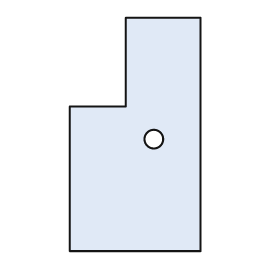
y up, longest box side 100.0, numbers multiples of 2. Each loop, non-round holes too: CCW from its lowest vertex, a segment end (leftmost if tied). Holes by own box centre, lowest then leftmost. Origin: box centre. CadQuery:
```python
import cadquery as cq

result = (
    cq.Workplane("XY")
    .moveTo(-28.0, -50.0)
    .lineTo(28.0, -50.0)
    .lineTo(28.0, 50.0)
    .lineTo(-4.0, 50.0)
    .lineTo(-4.0, 12.0)
    .lineTo(-28.0, 12.0)
    .close()
    .moveTo(8.0, -2.0)
    .circle(4.0)
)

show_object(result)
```